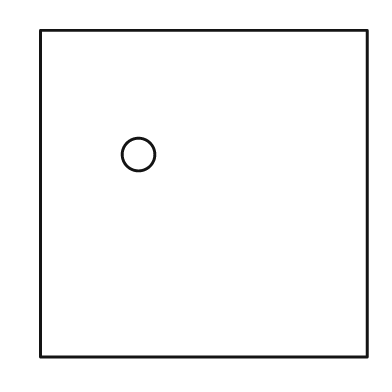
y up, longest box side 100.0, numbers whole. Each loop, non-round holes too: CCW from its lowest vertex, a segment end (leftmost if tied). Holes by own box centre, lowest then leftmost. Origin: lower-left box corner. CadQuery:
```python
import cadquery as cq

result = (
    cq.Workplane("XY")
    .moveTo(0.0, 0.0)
    .lineTo(100.0, 0.0)
    .lineTo(100.0, 100.0)
    .lineTo(0.0, 100.0)
    .close()
    .moveTo(30.0, 62.0)
    .circle(5.0)
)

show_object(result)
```